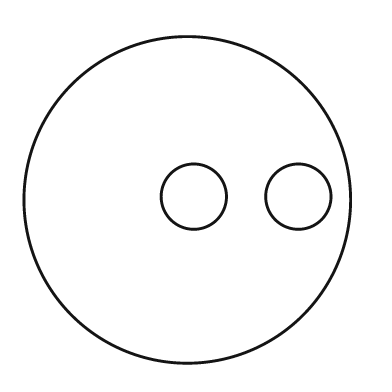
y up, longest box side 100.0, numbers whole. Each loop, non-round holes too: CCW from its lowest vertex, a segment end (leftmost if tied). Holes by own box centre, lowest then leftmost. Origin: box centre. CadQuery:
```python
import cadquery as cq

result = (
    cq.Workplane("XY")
    .moveTo(0.0, 0.0)
    .circle(50.0)
    .moveTo(2.0, 1.0)
    .circle(10.0)
    .moveTo(34.0, 1.0)
    .circle(10.0)
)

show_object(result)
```